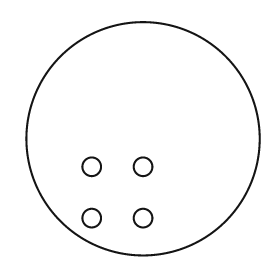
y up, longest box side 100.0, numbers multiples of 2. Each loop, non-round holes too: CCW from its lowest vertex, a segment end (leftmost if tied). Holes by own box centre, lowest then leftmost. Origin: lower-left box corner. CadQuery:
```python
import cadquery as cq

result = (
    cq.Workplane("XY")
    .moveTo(50.0, 50.0)
    .circle(50.0)
    .moveTo(28.0, 16.0)
    .circle(4.0)
    .moveTo(50.0, 16.0)
    .circle(4.0)
    .moveTo(28.0, 38.0)
    .circle(4.0)
    .moveTo(50.0, 38.0)
    .circle(4.0)
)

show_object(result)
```